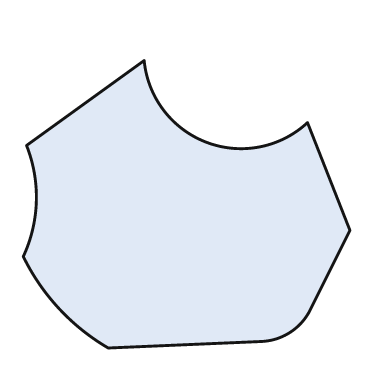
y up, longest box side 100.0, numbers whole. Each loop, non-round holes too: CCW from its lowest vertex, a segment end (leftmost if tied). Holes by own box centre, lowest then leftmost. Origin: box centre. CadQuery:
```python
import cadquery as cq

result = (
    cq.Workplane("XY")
    .moveTo(-24.0, -44.0)
    .lineTo(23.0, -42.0)
    .threePointArc((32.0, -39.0), (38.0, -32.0))
    .lineTo(50.0, -8.0)
    .lineTo(37.0, 25.0)
    .threePointArc((6.0, 19.0), (-13.0, 44.0))
    .lineTo(-49.0, 18.0)
    .threePointArc((-46.0, 1.0), (-50.0, -16.0))
    .threePointArc((-39.0, -32.0), (-24.0, -44.0))
    .close()
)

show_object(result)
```